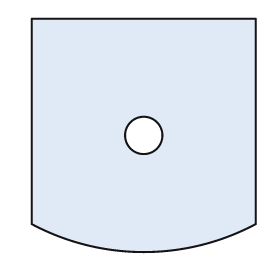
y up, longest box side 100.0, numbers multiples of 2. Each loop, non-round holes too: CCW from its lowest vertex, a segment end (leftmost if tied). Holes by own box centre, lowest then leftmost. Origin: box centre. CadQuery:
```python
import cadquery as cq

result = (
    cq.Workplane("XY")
    .moveTo(-48.0, -38.0)
    .threePointArc((0.0, -50.0), (48.0, -38.0))
    .lineTo(48.0, 50.0)
    .lineTo(-48.0, 50.0)
    .close()
    .moveTo(0.0, 0.0)
    .circle(8.0)
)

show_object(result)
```